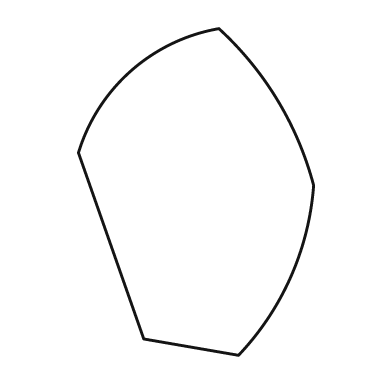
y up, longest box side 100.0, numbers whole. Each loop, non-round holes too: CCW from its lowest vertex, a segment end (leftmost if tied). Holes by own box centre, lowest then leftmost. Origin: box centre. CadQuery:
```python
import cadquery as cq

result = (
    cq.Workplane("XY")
    .moveTo(13.0, -50.0)
    .threePointArc((29.0, -26.0), (36.0, 2.0))
    .threePointArc((25.0, 28.0), (7.0, 50.0))
    .threePointArc((-20.0, 37.0), (-36.0, 12.0))
    .lineTo(-16.0, -45.0)
    .close()
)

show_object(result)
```